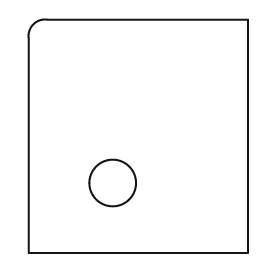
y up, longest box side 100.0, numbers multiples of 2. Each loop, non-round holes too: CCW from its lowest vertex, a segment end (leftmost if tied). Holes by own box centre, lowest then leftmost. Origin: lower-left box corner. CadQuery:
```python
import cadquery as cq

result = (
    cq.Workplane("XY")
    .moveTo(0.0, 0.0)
    .lineTo(94.0, 0.0)
    .lineTo(94.0, 100.0)
    .lineTo(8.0, 100.0)
    .threePointArc((2.0, 98.0), (0.0, 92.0))
    .close()
    .moveTo(36.0, 30.0)
    .circle(10.0)
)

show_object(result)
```